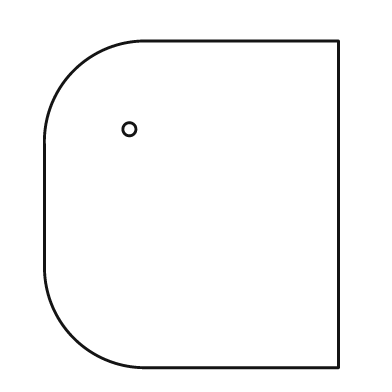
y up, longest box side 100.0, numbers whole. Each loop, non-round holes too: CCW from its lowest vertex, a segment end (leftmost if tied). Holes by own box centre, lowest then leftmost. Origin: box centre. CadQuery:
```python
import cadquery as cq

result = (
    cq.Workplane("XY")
    .moveTo(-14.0, -50.0)
    .lineTo(45.0, -50.0)
    .lineTo(45.0, 50.0)
    .lineTo(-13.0, 50.0)
    .threePointArc((-36.0, 41.0), (-45.0, 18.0))
    .lineTo(-45.0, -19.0)
    .threePointArc((-36.0, -41.0), (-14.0, -50.0))
    .close()
    .moveTo(-19.0, 23.0)
    .circle(2.0)
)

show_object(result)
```